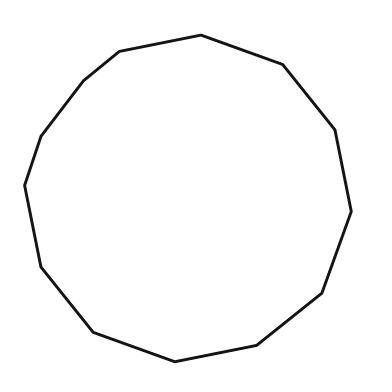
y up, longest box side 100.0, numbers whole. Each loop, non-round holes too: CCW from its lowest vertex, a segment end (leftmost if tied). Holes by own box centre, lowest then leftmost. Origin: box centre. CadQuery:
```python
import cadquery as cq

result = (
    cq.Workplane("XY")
    .moveTo(-4.0, -50.0)
    .lineTo(21.0, -45.0)
    .lineTo(41.0, -29.0)
    .lineTo(50.0, -4.0)
    .lineTo(45.0, 21.0)
    .lineTo(29.0, 41.0)
    .lineTo(4.0, 50.0)
    .lineTo(-21.0, 45.0)
    .lineTo(-32.0, 36.0)
    .lineTo(-45.0, 19.0)
    .lineTo(-50.0, 4.0)
    .lineTo(-45.0, -21.0)
    .lineTo(-29.0, -41.0)
    .close()
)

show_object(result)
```